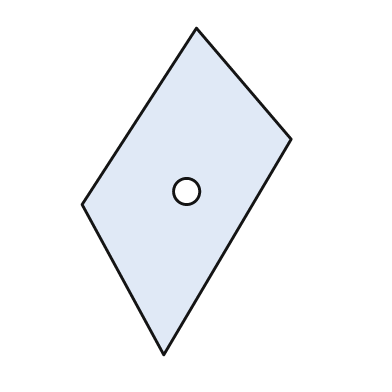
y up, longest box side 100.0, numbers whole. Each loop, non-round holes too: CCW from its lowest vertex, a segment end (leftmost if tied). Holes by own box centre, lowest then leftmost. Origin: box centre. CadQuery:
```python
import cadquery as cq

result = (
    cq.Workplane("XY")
    .moveTo(-7.0, -50.0)
    .lineTo(32.0, 16.0)
    .lineTo(3.0, 50.0)
    .lineTo(-32.0, -4.0)
    .close()
    .moveTo(0.0, 0.0)
    .circle(4.0)
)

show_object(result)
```